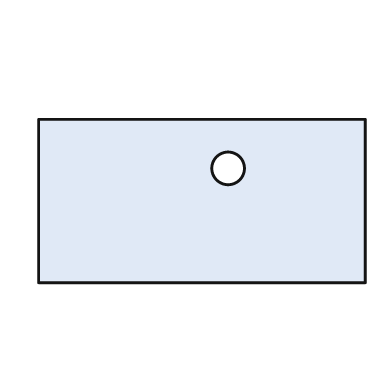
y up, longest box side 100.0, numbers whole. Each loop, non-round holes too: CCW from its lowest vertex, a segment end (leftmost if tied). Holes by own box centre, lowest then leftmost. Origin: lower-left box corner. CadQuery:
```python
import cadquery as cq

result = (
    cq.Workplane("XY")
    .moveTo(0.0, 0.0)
    .lineTo(100.0, 0.0)
    .lineTo(100.0, 50.0)
    .lineTo(0.0, 50.0)
    .close()
    .moveTo(58.0, 35.0)
    .circle(5.0)
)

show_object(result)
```